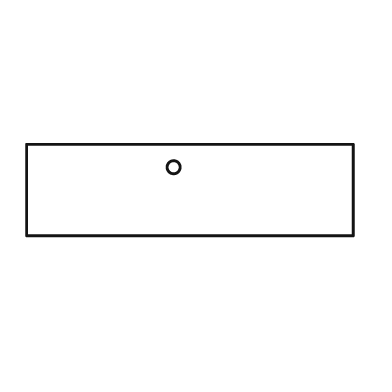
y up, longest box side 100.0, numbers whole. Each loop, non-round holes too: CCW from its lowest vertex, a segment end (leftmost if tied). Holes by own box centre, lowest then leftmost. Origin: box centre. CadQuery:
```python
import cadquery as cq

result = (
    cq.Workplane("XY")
    .moveTo(-50.0, -14.0)
    .lineTo(50.0, -14.0)
    .lineTo(50.0, 14.0)
    .lineTo(-50.0, 14.0)
    .close()
    .moveTo(-5.0, 7.0)
    .circle(2.0)
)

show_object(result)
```